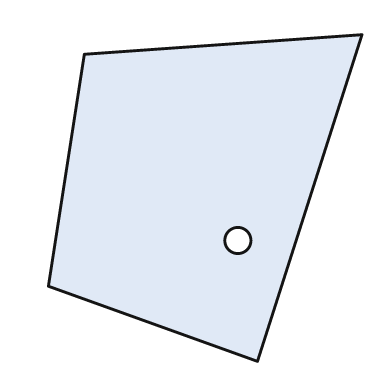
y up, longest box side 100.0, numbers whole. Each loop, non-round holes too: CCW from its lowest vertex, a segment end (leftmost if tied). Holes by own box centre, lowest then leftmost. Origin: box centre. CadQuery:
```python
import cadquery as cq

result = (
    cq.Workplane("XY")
    .moveTo(16.0, -50.0)
    .lineTo(48.0, 50.0)
    .lineTo(-37.0, 44.0)
    .lineTo(-48.0, -27.0)
    .close()
    .moveTo(10.0, -13.0)
    .circle(4.0)
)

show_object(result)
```